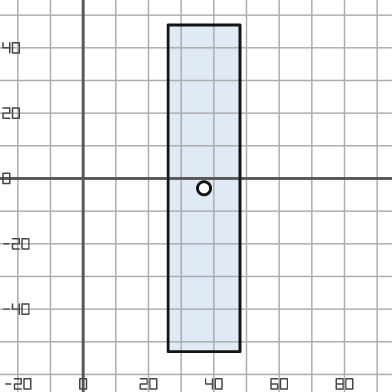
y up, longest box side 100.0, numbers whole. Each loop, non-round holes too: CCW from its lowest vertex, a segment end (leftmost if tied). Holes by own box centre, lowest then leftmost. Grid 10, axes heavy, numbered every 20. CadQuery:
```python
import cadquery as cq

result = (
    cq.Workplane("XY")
    .moveTo(26.0, -53.0)
    .lineTo(48.0, -53.0)
    .lineTo(48.0, 47.0)
    .lineTo(26.0, 47.0)
    .close()
    .moveTo(37.0, -3.0)
    .circle(2.0)
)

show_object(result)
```